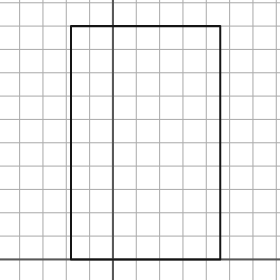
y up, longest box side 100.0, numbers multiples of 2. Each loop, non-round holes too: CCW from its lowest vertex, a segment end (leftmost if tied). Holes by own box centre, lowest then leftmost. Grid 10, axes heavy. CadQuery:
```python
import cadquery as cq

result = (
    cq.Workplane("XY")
    .moveTo(-18.0, 0.0)
    .lineTo(46.0, 0.0)
    .lineTo(46.0, 100.0)
    .lineTo(-18.0, 100.0)
    .close()
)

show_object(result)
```